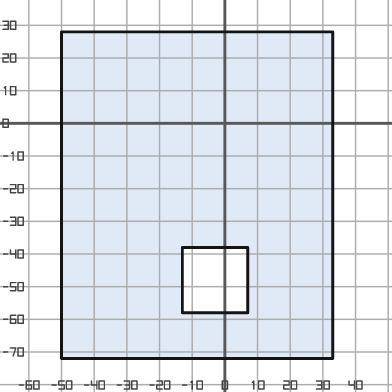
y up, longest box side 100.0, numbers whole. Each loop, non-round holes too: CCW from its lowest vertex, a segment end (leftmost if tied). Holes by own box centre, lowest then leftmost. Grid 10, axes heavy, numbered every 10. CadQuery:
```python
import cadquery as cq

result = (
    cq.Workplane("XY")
    .moveTo(-50.0, -72.0)
    .lineTo(33.0, -72.0)
    .lineTo(33.0, 28.0)
    .lineTo(-50.0, 28.0)
    .close()
    .moveTo(-13.0, -58.0)
    .lineTo(7.0, -58.0)
    .lineTo(7.0, -38.0)
    .lineTo(-13.0, -38.0)
    .close()
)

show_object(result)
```